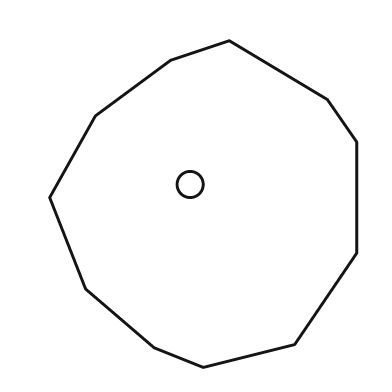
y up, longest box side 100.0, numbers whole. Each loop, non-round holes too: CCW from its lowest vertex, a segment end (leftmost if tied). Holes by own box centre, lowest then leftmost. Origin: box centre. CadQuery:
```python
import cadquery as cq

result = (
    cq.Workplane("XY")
    .moveTo(0.0, -50.0)
    .lineTo(28.0, -43.0)
    .lineTo(47.0, -15.0)
    .lineTo(47.0, 19.0)
    .lineTo(38.0, 32.0)
    .lineTo(8.0, 50.0)
    .lineTo(-10.0, 44.0)
    .lineTo(-33.0, 27.0)
    .lineTo(-47.0, 2.0)
    .lineTo(-36.0, -26.0)
    .lineTo(-15.0, -44.0)
    .close()
    .moveTo(-4.0, 6.0)
    .circle(4.0)
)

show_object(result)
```